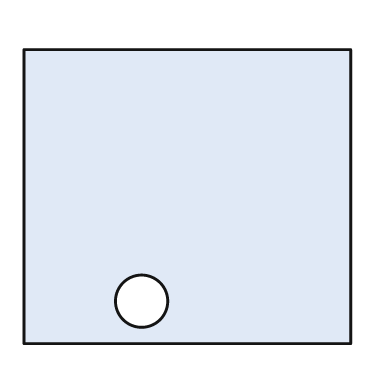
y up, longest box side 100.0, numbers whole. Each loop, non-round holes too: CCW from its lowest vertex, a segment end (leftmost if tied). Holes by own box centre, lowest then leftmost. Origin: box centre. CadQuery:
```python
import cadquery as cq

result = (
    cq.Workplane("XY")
    .moveTo(-50.0, -45.0)
    .lineTo(50.0, -45.0)
    .lineTo(50.0, 45.0)
    .lineTo(-50.0, 45.0)
    .close()
    .moveTo(-14.0, -32.0)
    .circle(8.0)
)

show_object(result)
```